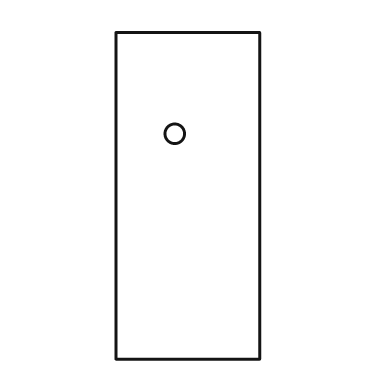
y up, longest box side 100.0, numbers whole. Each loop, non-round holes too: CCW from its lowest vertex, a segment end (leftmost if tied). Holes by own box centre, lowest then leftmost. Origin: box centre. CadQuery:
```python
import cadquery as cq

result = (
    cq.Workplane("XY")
    .moveTo(-22.0, -50.0)
    .lineTo(22.0, -50.0)
    .lineTo(22.0, 50.0)
    .lineTo(-22.0, 50.0)
    .close()
    .moveTo(-4.0, 19.0)
    .circle(3.0)
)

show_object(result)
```